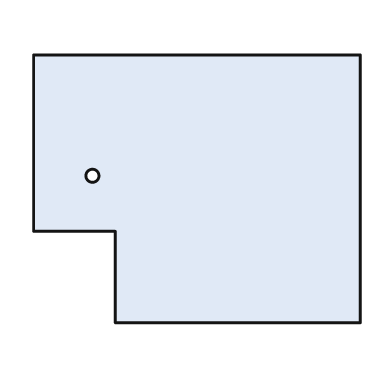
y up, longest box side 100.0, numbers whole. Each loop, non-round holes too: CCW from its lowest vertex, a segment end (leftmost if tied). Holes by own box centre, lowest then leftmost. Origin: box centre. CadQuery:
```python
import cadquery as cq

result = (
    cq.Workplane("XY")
    .moveTo(-25.0, -41.0)
    .lineTo(50.0, -41.0)
    .lineTo(50.0, 41.0)
    .lineTo(-50.0, 41.0)
    .lineTo(-50.0, -13.0)
    .lineTo(-25.0, -13.0)
    .close()
    .moveTo(-32.0, 4.0)
    .circle(2.0)
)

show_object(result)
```